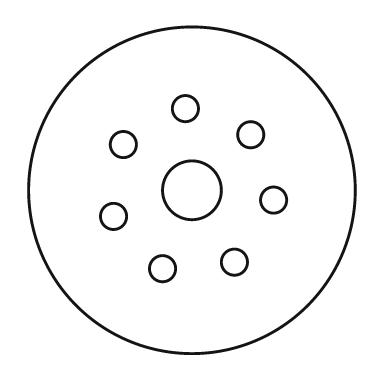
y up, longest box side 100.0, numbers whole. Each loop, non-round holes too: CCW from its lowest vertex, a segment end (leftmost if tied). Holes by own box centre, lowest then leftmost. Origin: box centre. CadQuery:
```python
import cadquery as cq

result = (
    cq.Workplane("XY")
    .moveTo(0.0, 0.0)
    .circle(50.0)
    .moveTo(-9.0, -24.0)
    .circle(4.0)
    .moveTo(13.0, -22.0)
    .circle(4.0)
    .moveTo(-24.0, -8.0)
    .circle(4.0)
    .moveTo(25.0, -3.0)
    .circle(4.0)
    .moveTo(0.0, 0.0)
    .circle(9.0)
    .moveTo(-21.0, 14.0)
    .circle(4.0)
    .moveTo(18.0, 17.0)
    .circle(4.0)
    .moveTo(-2.0, 25.0)
    .circle(4.0)
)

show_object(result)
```